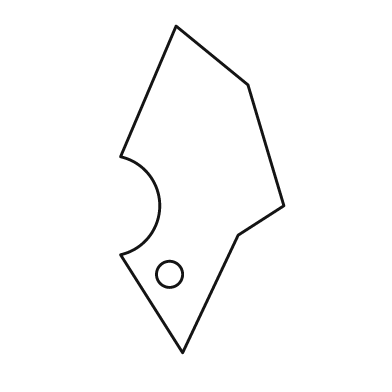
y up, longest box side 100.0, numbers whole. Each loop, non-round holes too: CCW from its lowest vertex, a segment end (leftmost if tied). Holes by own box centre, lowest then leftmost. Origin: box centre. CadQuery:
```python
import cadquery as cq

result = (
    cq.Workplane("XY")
    .moveTo(-6.0, -50.0)
    .lineTo(11.0, -14.0)
    .lineTo(25.0, -5.0)
    .lineTo(14.0, 32.0)
    .lineTo(-8.0, 50.0)
    .lineTo(-25.0, 10.0)
    .threePointArc((-13.0, -5.0), (-25.0, -20.0))
    .close()
    .moveTo(-10.0, -26.0)
    .circle(4.0)
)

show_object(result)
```